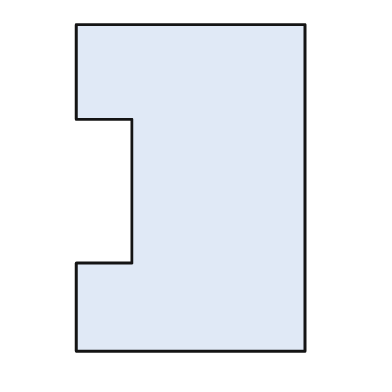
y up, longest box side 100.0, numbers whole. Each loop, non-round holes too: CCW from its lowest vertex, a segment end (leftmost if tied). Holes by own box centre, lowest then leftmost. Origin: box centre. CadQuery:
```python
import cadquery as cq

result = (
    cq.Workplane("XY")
    .moveTo(-35.0, -50.0)
    .lineTo(35.0, -50.0)
    .lineTo(35.0, 50.0)
    .lineTo(-35.0, 50.0)
    .lineTo(-35.0, 21.0)
    .lineTo(-18.0, 21.0)
    .lineTo(-18.0, -23.0)
    .lineTo(-35.0, -23.0)
    .close()
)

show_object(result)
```